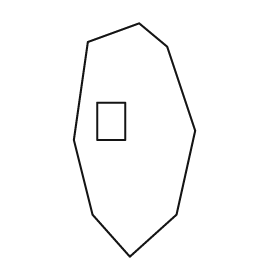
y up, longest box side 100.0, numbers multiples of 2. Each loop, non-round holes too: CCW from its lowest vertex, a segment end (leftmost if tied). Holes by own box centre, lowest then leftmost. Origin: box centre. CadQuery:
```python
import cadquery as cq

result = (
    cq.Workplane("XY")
    .moveTo(-2.0, -50.0)
    .lineTo(18.0, -32.0)
    .lineTo(26.0, 4.0)
    .lineTo(14.0, 40.0)
    .lineTo(2.0, 50.0)
    .lineTo(-20.0, 42.0)
    .lineTo(-26.0, 0.0)
    .lineTo(-18.0, -32.0)
    .close()
    .moveTo(-16.0, 0.0)
    .lineTo(-4.0, 0.0)
    .lineTo(-4.0, 16.0)
    .lineTo(-16.0, 16.0)
    .close()
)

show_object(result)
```